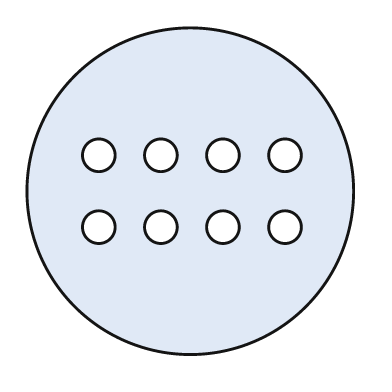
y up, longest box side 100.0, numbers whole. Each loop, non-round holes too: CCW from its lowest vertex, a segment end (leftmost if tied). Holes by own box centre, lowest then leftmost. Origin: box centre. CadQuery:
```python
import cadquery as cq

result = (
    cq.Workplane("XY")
    .moveTo(0.0, 0.0)
    .circle(50.0)
    .moveTo(-28.0, -11.0)
    .circle(5.0)
    .moveTo(-9.0, -11.0)
    .circle(5.0)
    .moveTo(10.0, -11.0)
    .circle(5.0)
    .moveTo(29.0, -11.0)
    .circle(5.0)
    .moveTo(-28.0, 11.0)
    .circle(5.0)
    .moveTo(-9.0, 11.0)
    .circle(5.0)
    .moveTo(10.0, 11.0)
    .circle(5.0)
    .moveTo(29.0, 11.0)
    .circle(5.0)
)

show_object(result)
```